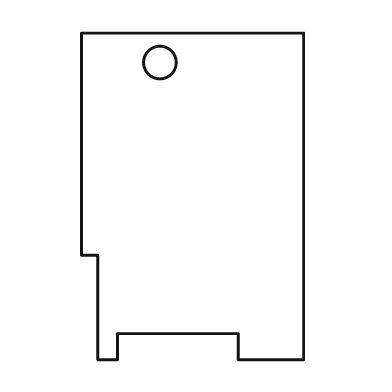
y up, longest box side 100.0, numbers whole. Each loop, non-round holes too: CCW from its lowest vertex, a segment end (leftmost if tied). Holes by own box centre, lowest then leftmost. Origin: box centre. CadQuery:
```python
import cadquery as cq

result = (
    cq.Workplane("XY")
    .moveTo(-29.0, -50.0)
    .lineTo(-23.0, -50.0)
    .lineTo(-23.0, -42.0)
    .lineTo(14.0, -42.0)
    .lineTo(14.0, -50.0)
    .lineTo(34.0, -50.0)
    .lineTo(34.0, 50.0)
    .lineTo(-34.0, 50.0)
    .lineTo(-34.0, -18.0)
    .lineTo(-29.0, -18.0)
    .close()
    .moveTo(-10.0, 41.0)
    .circle(5.0)
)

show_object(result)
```